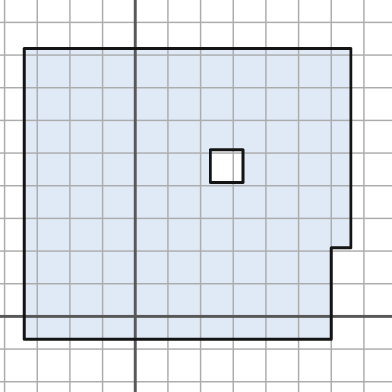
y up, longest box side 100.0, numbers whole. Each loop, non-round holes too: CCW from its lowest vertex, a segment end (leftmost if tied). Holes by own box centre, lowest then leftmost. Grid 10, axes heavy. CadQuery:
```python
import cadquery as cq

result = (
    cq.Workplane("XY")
    .moveTo(-34.0, -7.0)
    .lineTo(60.0, -7.0)
    .lineTo(60.0, 21.0)
    .lineTo(66.0, 21.0)
    .lineTo(66.0, 82.0)
    .lineTo(-34.0, 82.0)
    .close()
    .moveTo(23.0, 41.0)
    .lineTo(33.0, 41.0)
    .lineTo(33.0, 51.0)
    .lineTo(23.0, 51.0)
    .close()
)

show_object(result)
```